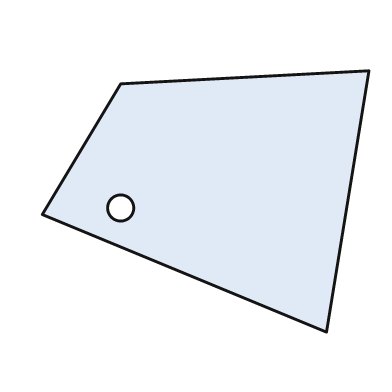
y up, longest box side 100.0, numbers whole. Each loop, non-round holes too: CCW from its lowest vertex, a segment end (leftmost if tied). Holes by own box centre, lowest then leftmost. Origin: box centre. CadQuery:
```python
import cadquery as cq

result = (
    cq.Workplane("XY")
    .moveTo(37.0, -40.0)
    .lineTo(50.0, 40.0)
    .lineTo(-26.0, 36.0)
    .lineTo(-50.0, -4.0)
    .close()
    .moveTo(-26.0, -2.0)
    .circle(4.0)
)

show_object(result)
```